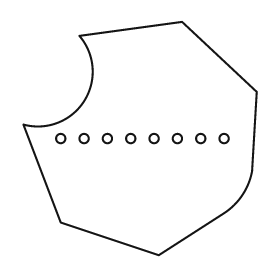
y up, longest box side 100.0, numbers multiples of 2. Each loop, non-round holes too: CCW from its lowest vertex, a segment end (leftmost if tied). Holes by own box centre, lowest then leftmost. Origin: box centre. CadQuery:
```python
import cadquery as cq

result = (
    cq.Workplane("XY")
    .moveTo(8.0, -50.0)
    .lineTo(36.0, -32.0)
    .threePointArc((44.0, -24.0), (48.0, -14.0))
    .lineTo(50.0, 20.0)
    .lineTo(18.0, 50.0)
    .lineTo(-26.0, 44.0)
    .threePointArc((-24.0, 16.0), (-50.0, 6.0))
    .lineTo(-34.0, -36.0)
    .close()
    .moveTo(-34.0, 0.0)
    .circle(2.0)
    .moveTo(-24.0, 0.0)
    .circle(2.0)
    .moveTo(-14.0, 0.0)
    .circle(2.0)
    .moveTo(-4.0, 0.0)
    .circle(2.0)
    .moveTo(6.0, 0.0)
    .circle(2.0)
    .moveTo(16.0, 0.0)
    .circle(2.0)
    .moveTo(26.0, 0.0)
    .circle(2.0)
    .moveTo(36.0, 0.0)
    .circle(2.0)
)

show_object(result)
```